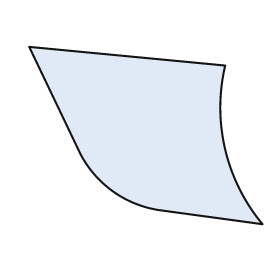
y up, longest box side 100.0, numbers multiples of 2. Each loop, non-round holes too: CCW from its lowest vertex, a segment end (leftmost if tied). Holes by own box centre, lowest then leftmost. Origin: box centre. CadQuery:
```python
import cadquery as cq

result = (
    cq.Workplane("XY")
    .moveTo(50.0, -38.0)
    .threePointArc((34.0, -6.0), (34.0, 30.0))
    .lineTo(-50.0, 38.0)
    .lineTo(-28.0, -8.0)
    .threePointArc((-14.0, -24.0), (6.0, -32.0))
    .close()
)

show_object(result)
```